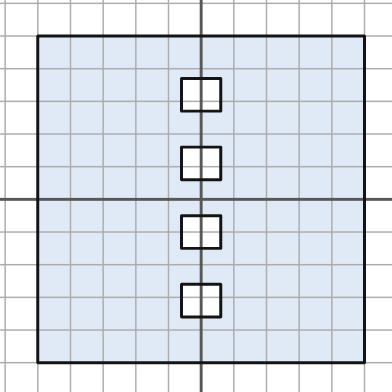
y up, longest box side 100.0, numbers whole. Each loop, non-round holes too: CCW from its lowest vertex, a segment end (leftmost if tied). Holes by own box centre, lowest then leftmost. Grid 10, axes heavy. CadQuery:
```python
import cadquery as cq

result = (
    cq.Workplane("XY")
    .moveTo(-50.0, -50.0)
    .lineTo(50.0, -50.0)
    .lineTo(50.0, 50.0)
    .lineTo(-50.0, 50.0)
    .close()
    .moveTo(-6.0, -36.0)
    .lineTo(6.0, -36.0)
    .lineTo(6.0, -26.0)
    .lineTo(-6.0, -26.0)
    .close()
    .moveTo(-6.0, -15.0)
    .lineTo(6.0, -15.0)
    .lineTo(6.0, -5.0)
    .lineTo(-6.0, -5.0)
    .close()
    .moveTo(-6.0, 6.0)
    .lineTo(6.0, 6.0)
    .lineTo(6.0, 16.0)
    .lineTo(-6.0, 16.0)
    .close()
    .moveTo(-6.0, 27.0)
    .lineTo(6.0, 27.0)
    .lineTo(6.0, 37.0)
    .lineTo(-6.0, 37.0)
    .close()
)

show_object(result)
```